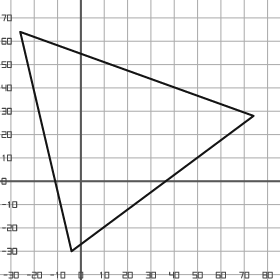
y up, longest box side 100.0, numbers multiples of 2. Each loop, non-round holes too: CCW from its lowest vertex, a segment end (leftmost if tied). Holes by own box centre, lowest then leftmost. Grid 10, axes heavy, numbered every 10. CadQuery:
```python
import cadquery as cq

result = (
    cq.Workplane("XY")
    .moveTo(-4.0, -30.0)
    .lineTo(74.0, 28.0)
    .lineTo(-26.0, 64.0)
    .close()
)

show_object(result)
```